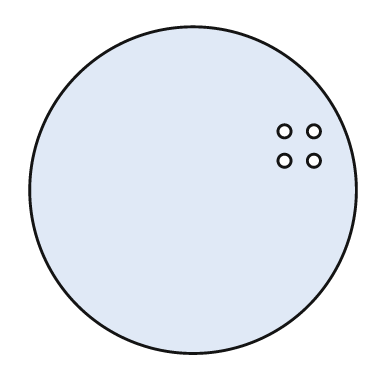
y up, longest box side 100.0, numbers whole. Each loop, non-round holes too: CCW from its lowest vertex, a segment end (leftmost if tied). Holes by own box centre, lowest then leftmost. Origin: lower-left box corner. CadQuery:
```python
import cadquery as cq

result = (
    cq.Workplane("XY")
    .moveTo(50.0, 50.0)
    .circle(50.0)
    .moveTo(78.0, 59.0)
    .circle(2.0)
    .moveTo(87.0, 59.0)
    .circle(2.0)
    .moveTo(78.0, 68.0)
    .circle(2.0)
    .moveTo(87.0, 68.0)
    .circle(2.0)
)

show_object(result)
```